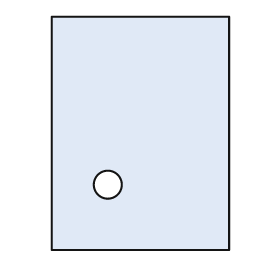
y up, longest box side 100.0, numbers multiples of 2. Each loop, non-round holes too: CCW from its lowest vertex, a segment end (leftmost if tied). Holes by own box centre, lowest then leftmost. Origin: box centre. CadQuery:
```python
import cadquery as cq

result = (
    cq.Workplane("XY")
    .moveTo(-38.0, -50.0)
    .lineTo(38.0, -50.0)
    .lineTo(38.0, 50.0)
    .lineTo(-38.0, 50.0)
    .close()
    .moveTo(-14.0, -22.0)
    .circle(6.0)
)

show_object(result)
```